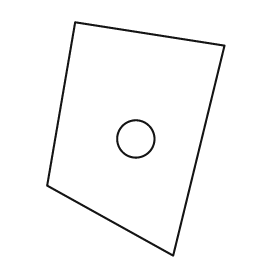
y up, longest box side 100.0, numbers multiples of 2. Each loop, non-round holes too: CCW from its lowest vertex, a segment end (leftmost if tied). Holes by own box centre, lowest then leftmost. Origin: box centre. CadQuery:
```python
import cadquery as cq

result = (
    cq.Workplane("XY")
    .moveTo(16.0, -50.0)
    .lineTo(38.0, 40.0)
    .lineTo(-26.0, 50.0)
    .lineTo(-38.0, -20.0)
    .close()
    .moveTo(0.0, 0.0)
    .circle(8.0)
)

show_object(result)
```